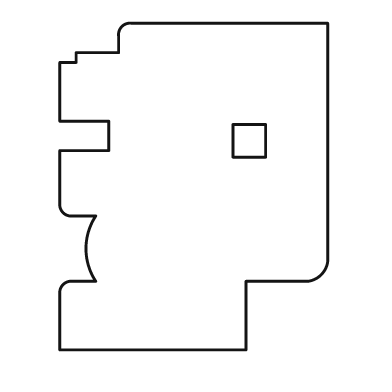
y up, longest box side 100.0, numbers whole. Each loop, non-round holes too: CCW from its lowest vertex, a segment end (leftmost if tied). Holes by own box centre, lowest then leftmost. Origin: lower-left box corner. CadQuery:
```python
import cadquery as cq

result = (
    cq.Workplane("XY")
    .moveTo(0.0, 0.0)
    .lineTo(57.0, 0.0)
    .lineTo(57.0, 21.0)
    .lineTo(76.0, 21.0)
    .threePointArc((80.0, 23.0), (82.0, 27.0))
    .lineTo(82.0, 100.0)
    .lineTo(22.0, 100.0)
    .threePointArc((19.0, 99.0), (18.0, 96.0))
    .lineTo(18.0, 91.0)
    .lineTo(5.0, 91.0)
    .lineTo(5.0, 88.0)
    .lineTo(0.0, 88.0)
    .lineTo(0.0, 70.0)
    .lineTo(15.0, 70.0)
    .lineTo(15.0, 61.0)
    .lineTo(0.0, 61.0)
    .lineTo(0.0, 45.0)
    .threePointArc((1.0, 42.0), (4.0, 41.0))
    .lineTo(11.0, 41.0)
    .threePointArc((8.0, 31.0), (11.0, 21.0))
    .lineTo(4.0, 21.0)
    .threePointArc((1.0, 20.0), (0.0, 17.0))
    .close()
    .moveTo(53.0, 59.0)
    .lineTo(63.0, 59.0)
    .lineTo(63.0, 69.0)
    .lineTo(53.0, 69.0)
    .close()
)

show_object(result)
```